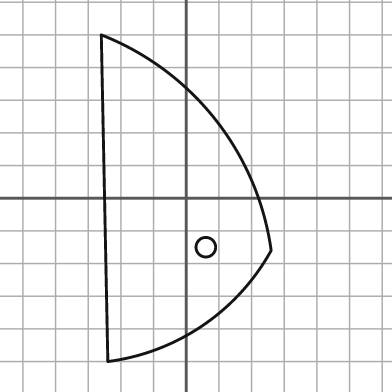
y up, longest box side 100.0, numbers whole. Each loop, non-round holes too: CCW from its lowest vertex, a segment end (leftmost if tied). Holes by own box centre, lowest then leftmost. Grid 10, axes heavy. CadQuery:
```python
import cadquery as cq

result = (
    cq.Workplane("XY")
    .moveTo(-24.0, -50.0)
    .threePointArc((5.0, -39.0), (26.0, -16.0))
    .threePointArc((9.0, 24.0), (-26.0, 50.0))
    .close()
    .moveTo(6.0, -15.0)
    .circle(3.0)
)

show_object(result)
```